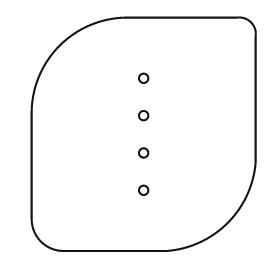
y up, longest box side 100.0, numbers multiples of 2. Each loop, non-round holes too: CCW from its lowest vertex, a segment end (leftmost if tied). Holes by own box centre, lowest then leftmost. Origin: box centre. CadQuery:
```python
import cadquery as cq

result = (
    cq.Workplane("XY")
    .moveTo(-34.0, -50.0)
    .lineTo(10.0, -50.0)
    .threePointArc((36.0, -38.0), (48.0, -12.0))
    .lineTo(48.0, 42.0)
    .threePointArc((46.0, 48.0), (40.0, 50.0))
    .lineTo(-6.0, 50.0)
    .threePointArc((-36.0, 38.0), (-48.0, 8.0))
    .lineTo(-48.0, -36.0)
    .threePointArc((-44.0, -46.0), (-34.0, -50.0))
    .close()
    .moveTo(0.0, -24.0)
    .circle(2.0)
    .moveTo(0.0, -8.0)
    .circle(2.0)
    .moveTo(0.0, 8.0)
    .circle(2.0)
    .moveTo(0.0, 24.0)
    .circle(2.0)
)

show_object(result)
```